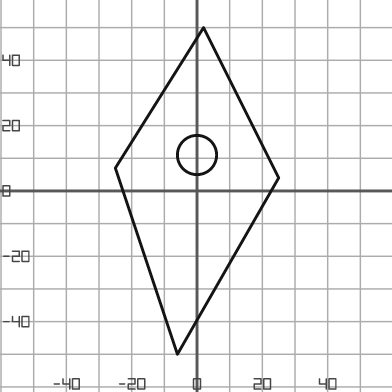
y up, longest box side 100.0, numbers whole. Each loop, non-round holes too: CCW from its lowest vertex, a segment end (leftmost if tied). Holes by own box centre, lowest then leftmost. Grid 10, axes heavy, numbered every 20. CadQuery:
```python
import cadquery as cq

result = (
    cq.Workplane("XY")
    .moveTo(-6.0, -50.0)
    .lineTo(25.0, 4.0)
    .lineTo(2.0, 50.0)
    .lineTo(-25.0, 7.0)
    .close()
    .moveTo(0.0, 11.0)
    .circle(6.0)
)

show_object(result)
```